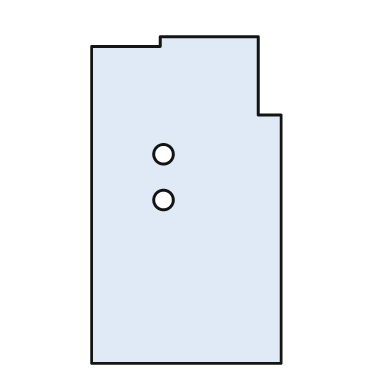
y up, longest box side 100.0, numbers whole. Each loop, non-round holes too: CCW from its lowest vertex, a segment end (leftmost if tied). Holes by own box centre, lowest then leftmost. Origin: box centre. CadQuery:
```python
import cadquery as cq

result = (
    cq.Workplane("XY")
    .moveTo(-29.0, -50.0)
    .lineTo(29.0, -50.0)
    .lineTo(29.0, 26.0)
    .lineTo(22.0, 26.0)
    .lineTo(22.0, 50.0)
    .lineTo(-8.0, 50.0)
    .lineTo(-8.0, 47.0)
    .lineTo(-29.0, 47.0)
    .close()
    .moveTo(-7.0, 0.0)
    .circle(3.0)
    .moveTo(-7.0, 14.0)
    .circle(3.0)
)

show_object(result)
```